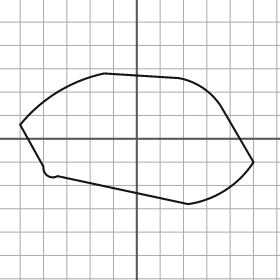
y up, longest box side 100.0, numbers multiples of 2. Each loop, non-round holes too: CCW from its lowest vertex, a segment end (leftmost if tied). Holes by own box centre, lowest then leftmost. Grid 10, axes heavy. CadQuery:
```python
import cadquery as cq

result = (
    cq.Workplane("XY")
    .moveTo(22.0, -28.0)
    .threePointArc((38.0, -22.0), (50.0, -10.0))
    .lineTo(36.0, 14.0)
    .threePointArc((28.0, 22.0), (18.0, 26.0))
    .lineTo(-14.0, 28.0)
    .threePointArc((-34.0, 20.0), (-50.0, 6.0))
    .lineTo(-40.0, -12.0)
    .threePointArc((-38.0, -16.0), (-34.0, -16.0))
    .close()
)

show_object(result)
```